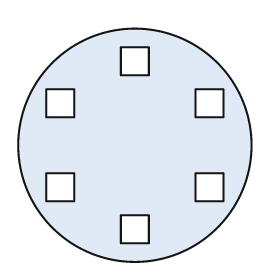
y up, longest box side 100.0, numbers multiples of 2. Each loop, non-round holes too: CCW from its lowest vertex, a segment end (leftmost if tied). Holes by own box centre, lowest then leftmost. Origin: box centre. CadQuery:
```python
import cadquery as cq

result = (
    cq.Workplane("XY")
    .moveTo(0.0, 0.0)
    .circle(50.0)
    .moveTo(-6.0, -42.0)
    .lineTo(6.0, -42.0)
    .lineTo(6.0, -30.0)
    .lineTo(-6.0, -30.0)
    .close()
    .moveTo(-38.0, -24.0)
    .lineTo(-26.0, -24.0)
    .lineTo(-26.0, -12.0)
    .lineTo(-38.0, -12.0)
    .close()
    .moveTo(26.0, -24.0)
    .lineTo(38.0, -24.0)
    .lineTo(38.0, -12.0)
    .lineTo(26.0, -12.0)
    .close()
    .moveTo(-38.0, 12.0)
    .lineTo(-26.0, 12.0)
    .lineTo(-26.0, 24.0)
    .lineTo(-38.0, 24.0)
    .close()
    .moveTo(26.0, 12.0)
    .lineTo(38.0, 12.0)
    .lineTo(38.0, 24.0)
    .lineTo(26.0, 24.0)
    .close()
    .moveTo(-6.0, 30.0)
    .lineTo(6.0, 30.0)
    .lineTo(6.0, 42.0)
    .lineTo(-6.0, 42.0)
    .close()
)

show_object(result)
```